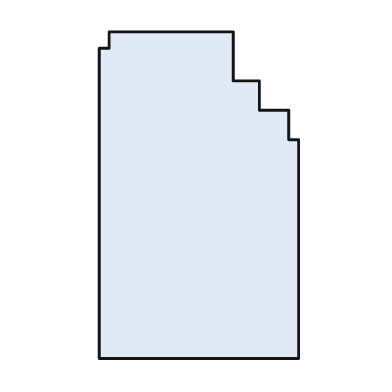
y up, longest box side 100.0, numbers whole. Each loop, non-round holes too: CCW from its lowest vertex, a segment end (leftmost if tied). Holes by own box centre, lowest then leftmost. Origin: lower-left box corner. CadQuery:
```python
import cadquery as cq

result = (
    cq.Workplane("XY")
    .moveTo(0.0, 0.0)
    .lineTo(61.0, 0.0)
    .lineTo(61.0, 67.0)
    .lineTo(58.0, 67.0)
    .lineTo(58.0, 76.0)
    .lineTo(49.0, 76.0)
    .lineTo(49.0, 85.0)
    .lineTo(41.0, 85.0)
    .lineTo(41.0, 100.0)
    .lineTo(3.0, 100.0)
    .lineTo(3.0, 95.0)
    .lineTo(0.0, 95.0)
    .close()
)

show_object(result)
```